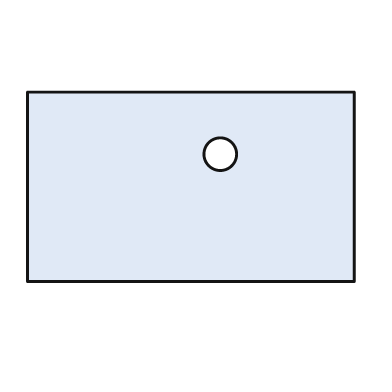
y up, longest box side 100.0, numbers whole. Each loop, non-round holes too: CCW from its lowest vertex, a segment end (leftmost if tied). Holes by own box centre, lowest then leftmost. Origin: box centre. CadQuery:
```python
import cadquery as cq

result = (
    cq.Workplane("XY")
    .moveTo(-50.0, -29.0)
    .lineTo(50.0, -29.0)
    .lineTo(50.0, 29.0)
    .lineTo(-50.0, 29.0)
    .close()
    .moveTo(9.0, 10.0)
    .circle(5.0)
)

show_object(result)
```